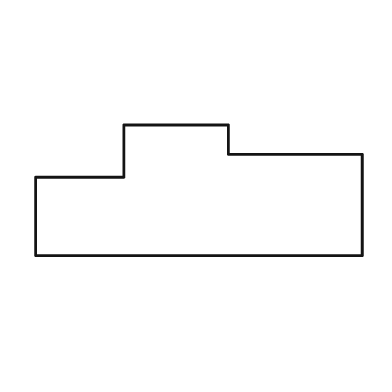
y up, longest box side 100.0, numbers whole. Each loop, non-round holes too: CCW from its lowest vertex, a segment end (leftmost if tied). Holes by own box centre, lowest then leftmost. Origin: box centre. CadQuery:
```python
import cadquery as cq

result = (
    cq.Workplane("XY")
    .moveTo(-50.0, -20.0)
    .lineTo(50.0, -20.0)
    .lineTo(50.0, 11.0)
    .lineTo(9.0, 11.0)
    .lineTo(9.0, 20.0)
    .lineTo(-23.0, 20.0)
    .lineTo(-23.0, 4.0)
    .lineTo(-50.0, 4.0)
    .close()
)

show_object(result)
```